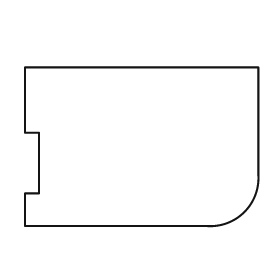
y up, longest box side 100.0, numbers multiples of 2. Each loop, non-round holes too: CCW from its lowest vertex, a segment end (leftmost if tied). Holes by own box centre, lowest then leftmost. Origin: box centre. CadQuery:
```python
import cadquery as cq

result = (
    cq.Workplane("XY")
    .moveTo(-50.0, -34.0)
    .lineTo(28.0, -34.0)
    .threePointArc((44.0, -28.0), (50.0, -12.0))
    .lineTo(50.0, 34.0)
    .lineTo(-50.0, 34.0)
    .lineTo(-50.0, 6.0)
    .lineTo(-44.0, 6.0)
    .lineTo(-44.0, -20.0)
    .lineTo(-50.0, -20.0)
    .close()
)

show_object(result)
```